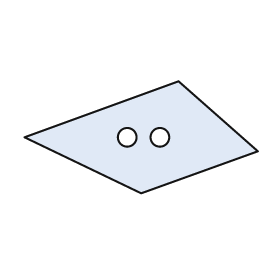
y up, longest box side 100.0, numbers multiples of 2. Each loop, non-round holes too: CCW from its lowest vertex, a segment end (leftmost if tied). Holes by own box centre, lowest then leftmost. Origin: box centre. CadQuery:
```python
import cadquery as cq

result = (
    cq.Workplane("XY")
    .moveTo(0.0, -24.0)
    .lineTo(50.0, -6.0)
    .lineTo(16.0, 24.0)
    .lineTo(-50.0, 0.0)
    .close()
    .moveTo(-6.0, 0.0)
    .circle(4.0)
    .moveTo(8.0, 0.0)
    .circle(4.0)
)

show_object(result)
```